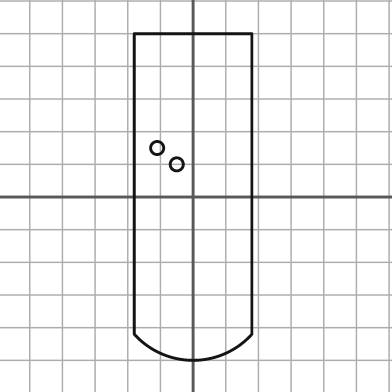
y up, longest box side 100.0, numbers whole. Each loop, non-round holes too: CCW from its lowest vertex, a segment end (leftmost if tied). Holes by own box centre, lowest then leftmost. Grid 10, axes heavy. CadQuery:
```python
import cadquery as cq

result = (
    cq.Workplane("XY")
    .moveTo(-18.0, -42.0)
    .threePointArc((0.0, -50.0), (18.0, -42.0))
    .lineTo(18.0, 50.0)
    .lineTo(-18.0, 50.0)
    .close()
    .moveTo(-5.0, 10.0)
    .circle(2.0)
    .moveTo(-11.0, 15.0)
    .circle(2.0)
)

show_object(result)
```